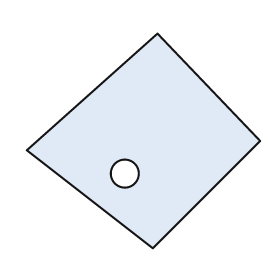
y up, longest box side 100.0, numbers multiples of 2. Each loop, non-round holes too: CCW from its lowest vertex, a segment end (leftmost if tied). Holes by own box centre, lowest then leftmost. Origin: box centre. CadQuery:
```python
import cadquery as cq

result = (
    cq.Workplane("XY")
    .moveTo(4.0, -46.0)
    .lineTo(50.0, 0.0)
    .lineTo(6.0, 46.0)
    .lineTo(-50.0, -4.0)
    .close()
    .moveTo(-8.0, -14.0)
    .circle(6.0)
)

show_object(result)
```